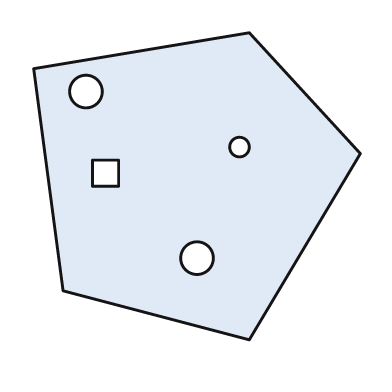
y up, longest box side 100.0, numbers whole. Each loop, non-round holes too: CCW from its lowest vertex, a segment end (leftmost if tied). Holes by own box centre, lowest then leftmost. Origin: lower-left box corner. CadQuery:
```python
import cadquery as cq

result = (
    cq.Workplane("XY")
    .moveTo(66.0, 0.0)
    .lineTo(100.0, 57.0)
    .lineTo(66.0, 94.0)
    .lineTo(0.0, 83.0)
    .lineTo(9.0, 15.0)
    .close()
    .moveTo(50.0, 25.0)
    .circle(5.0)
    .moveTo(18.0, 47.0)
    .lineTo(26.0, 47.0)
    .lineTo(26.0, 55.0)
    .lineTo(18.0, 55.0)
    .close()
    .moveTo(63.0, 59.0)
    .circle(3.0)
    .moveTo(16.0, 76.0)
    .circle(5.0)
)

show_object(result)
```